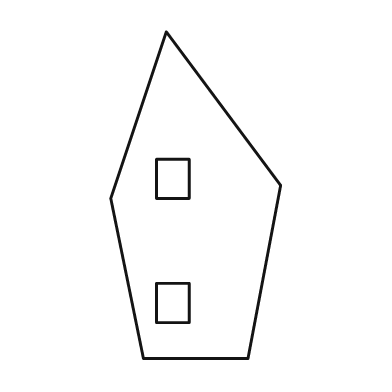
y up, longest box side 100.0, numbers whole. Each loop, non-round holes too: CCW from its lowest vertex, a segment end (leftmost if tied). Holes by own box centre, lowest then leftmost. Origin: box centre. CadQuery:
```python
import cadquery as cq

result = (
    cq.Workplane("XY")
    .moveTo(-16.0, -50.0)
    .lineTo(16.0, -50.0)
    .lineTo(26.0, 3.0)
    .lineTo(-9.0, 50.0)
    .lineTo(-26.0, -1.0)
    .close()
    .moveTo(-12.0, -39.0)
    .lineTo(-2.0, -39.0)
    .lineTo(-2.0, -27.0)
    .lineTo(-12.0, -27.0)
    .close()
    .moveTo(-12.0, -1.0)
    .lineTo(-2.0, -1.0)
    .lineTo(-2.0, 11.0)
    .lineTo(-12.0, 11.0)
    .close()
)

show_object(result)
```